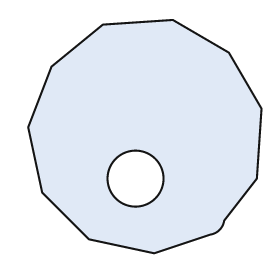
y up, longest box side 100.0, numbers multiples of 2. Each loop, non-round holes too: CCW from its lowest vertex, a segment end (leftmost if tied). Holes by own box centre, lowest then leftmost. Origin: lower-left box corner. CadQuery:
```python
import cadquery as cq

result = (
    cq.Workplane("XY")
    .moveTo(54.0, 0.0)
    .lineTo(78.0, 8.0)
    .threePointArc((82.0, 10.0), (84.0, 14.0))
    .lineTo(98.0, 32.0)
    .lineTo(100.0, 62.0)
    .lineTo(86.0, 86.0)
    .lineTo(62.0, 100.0)
    .lineTo(32.0, 98.0)
    .lineTo(10.0, 80.0)
    .lineTo(0.0, 54.0)
    .lineTo(6.0, 26.0)
    .lineTo(26.0, 6.0)
    .close()
    .moveTo(46.0, 32.0)
    .circle(12.0)
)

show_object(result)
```